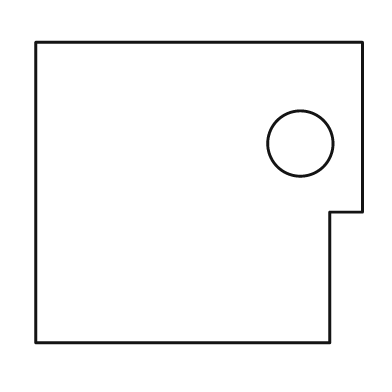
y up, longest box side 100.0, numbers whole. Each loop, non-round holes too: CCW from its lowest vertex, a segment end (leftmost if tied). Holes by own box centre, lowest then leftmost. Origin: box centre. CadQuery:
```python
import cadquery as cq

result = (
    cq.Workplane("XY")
    .moveTo(-50.0, -46.0)
    .lineTo(40.0, -46.0)
    .lineTo(40.0, -6.0)
    .lineTo(50.0, -6.0)
    .lineTo(50.0, 46.0)
    .lineTo(-50.0, 46.0)
    .close()
    .moveTo(31.0, 15.0)
    .circle(10.0)
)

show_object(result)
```